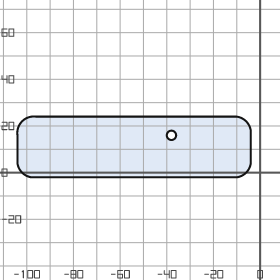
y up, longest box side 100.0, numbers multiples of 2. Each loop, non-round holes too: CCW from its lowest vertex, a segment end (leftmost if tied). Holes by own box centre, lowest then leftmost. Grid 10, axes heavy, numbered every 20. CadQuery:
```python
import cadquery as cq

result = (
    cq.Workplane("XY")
    .moveTo(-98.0, -2.0)
    .lineTo(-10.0, -2.0)
    .threePointArc((-6.0, 0.0), (-4.0, 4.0))
    .lineTo(-4.0, 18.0)
    .threePointArc((-6.0, 22.0), (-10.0, 24.0))
    .lineTo(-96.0, 24.0)
    .threePointArc((-102.0, 22.0), (-104.0, 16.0))
    .lineTo(-104.0, 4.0)
    .threePointArc((-102.0, 0.0), (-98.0, -2.0))
    .close()
    .moveTo(-38.0, 16.0)
    .circle(2.0)
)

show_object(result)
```